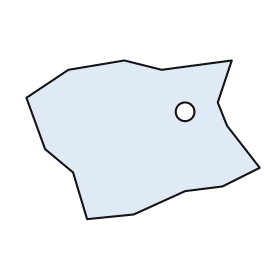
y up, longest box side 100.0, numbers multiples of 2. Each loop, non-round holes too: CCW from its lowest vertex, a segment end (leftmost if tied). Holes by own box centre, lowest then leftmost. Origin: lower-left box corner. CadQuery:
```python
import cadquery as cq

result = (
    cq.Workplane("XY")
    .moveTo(26.0, 0.0)
    .lineTo(46.0, 2.0)
    .lineTo(68.0, 12.0)
    .lineTo(84.0, 14.0)
    .lineTo(100.0, 22.0)
    .lineTo(86.0, 40.0)
    .lineTo(82.0, 50.0)
    .lineTo(88.0, 68.0)
    .lineTo(58.0, 64.0)
    .lineTo(42.0, 68.0)
    .lineTo(18.0, 64.0)
    .lineTo(0.0, 52.0)
    .lineTo(8.0, 30.0)
    .lineTo(20.0, 20.0)
    .close()
    .moveTo(68.0, 46.0)
    .circle(4.0)
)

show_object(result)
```